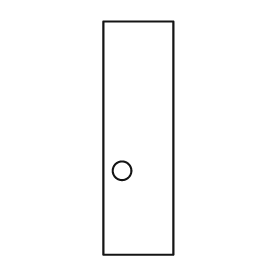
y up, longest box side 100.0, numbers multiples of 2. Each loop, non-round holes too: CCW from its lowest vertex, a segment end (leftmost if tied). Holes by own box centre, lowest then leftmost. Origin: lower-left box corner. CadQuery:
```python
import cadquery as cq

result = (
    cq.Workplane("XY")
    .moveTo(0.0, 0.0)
    .lineTo(30.0, 0.0)
    .lineTo(30.0, 100.0)
    .lineTo(0.0, 100.0)
    .close()
    .moveTo(8.0, 36.0)
    .circle(4.0)
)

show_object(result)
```